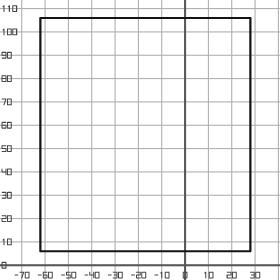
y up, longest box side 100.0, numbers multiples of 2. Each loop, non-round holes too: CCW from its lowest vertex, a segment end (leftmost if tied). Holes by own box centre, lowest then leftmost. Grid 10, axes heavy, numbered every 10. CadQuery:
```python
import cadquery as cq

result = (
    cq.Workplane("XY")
    .moveTo(-62.0, 6.0)
    .lineTo(28.0, 6.0)
    .lineTo(28.0, 106.0)
    .lineTo(-62.0, 106.0)
    .close()
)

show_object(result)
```